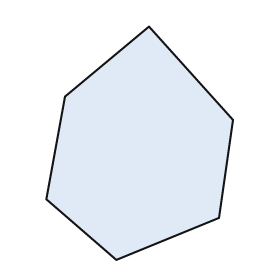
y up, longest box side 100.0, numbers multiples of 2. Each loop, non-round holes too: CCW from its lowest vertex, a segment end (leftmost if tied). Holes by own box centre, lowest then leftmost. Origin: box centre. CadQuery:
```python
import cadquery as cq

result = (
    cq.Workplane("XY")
    .moveTo(-10.0, -50.0)
    .lineTo(34.0, -32.0)
    .lineTo(40.0, 10.0)
    .lineTo(4.0, 50.0)
    .lineTo(-32.0, 20.0)
    .lineTo(-40.0, -24.0)
    .close()
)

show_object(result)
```